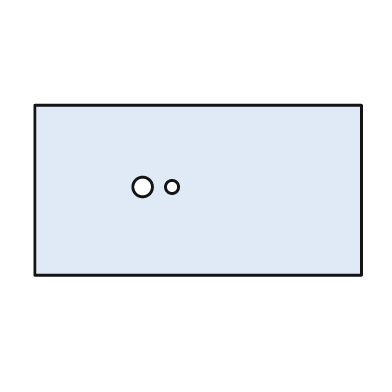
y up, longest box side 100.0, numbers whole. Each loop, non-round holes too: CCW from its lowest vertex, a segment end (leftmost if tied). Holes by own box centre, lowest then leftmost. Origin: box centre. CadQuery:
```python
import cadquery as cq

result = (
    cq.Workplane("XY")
    .moveTo(-50.0, -26.0)
    .lineTo(50.0, -26.0)
    .lineTo(50.0, 26.0)
    .lineTo(-50.0, 26.0)
    .close()
    .moveTo(-17.0, 1.0)
    .circle(3.0)
    .moveTo(-8.0, 1.0)
    .circle(2.0)
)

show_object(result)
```